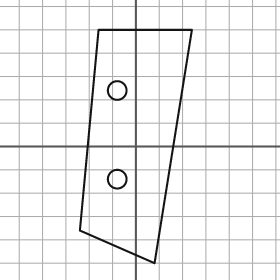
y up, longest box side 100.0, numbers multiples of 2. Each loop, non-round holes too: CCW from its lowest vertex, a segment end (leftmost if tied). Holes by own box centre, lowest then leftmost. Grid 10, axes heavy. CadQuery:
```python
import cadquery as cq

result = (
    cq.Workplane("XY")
    .moveTo(8.0, -50.0)
    .lineTo(24.0, 50.0)
    .lineTo(-16.0, 50.0)
    .lineTo(-24.0, -36.0)
    .close()
    .moveTo(-8.0, -14.0)
    .circle(4.0)
    .moveTo(-8.0, 24.0)
    .circle(4.0)
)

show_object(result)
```